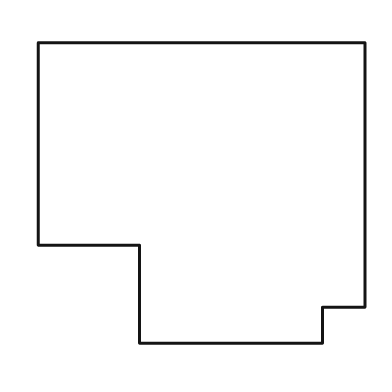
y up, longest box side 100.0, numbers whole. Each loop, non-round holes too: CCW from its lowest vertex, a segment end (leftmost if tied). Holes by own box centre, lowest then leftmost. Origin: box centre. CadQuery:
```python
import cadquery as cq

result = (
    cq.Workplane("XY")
    .moveTo(-19.0, -46.0)
    .lineTo(37.0, -46.0)
    .lineTo(37.0, -35.0)
    .lineTo(50.0, -35.0)
    .lineTo(50.0, 46.0)
    .lineTo(-50.0, 46.0)
    .lineTo(-50.0, -16.0)
    .lineTo(-19.0, -16.0)
    .close()
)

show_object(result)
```